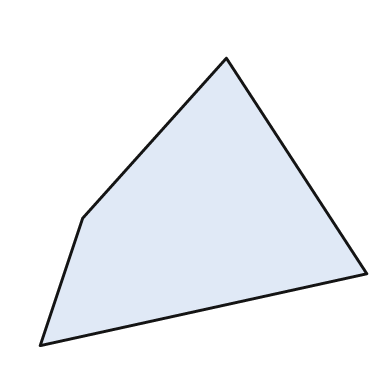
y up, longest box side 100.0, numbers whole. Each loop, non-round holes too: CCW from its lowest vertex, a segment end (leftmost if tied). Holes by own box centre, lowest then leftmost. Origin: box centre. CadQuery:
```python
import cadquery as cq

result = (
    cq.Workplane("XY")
    .moveTo(-50.0, -44.0)
    .lineTo(50.0, -22.0)
    .lineTo(7.0, 44.0)
    .lineTo(-37.0, -5.0)
    .close()
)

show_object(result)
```